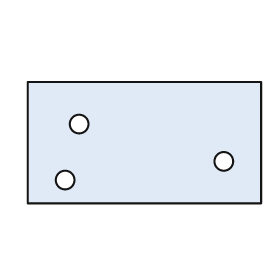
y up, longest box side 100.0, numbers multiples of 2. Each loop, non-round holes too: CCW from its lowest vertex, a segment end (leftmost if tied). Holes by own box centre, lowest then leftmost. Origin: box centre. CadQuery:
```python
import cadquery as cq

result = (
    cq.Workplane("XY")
    .moveTo(-50.0, -26.0)
    .lineTo(50.0, -26.0)
    .lineTo(50.0, 26.0)
    .lineTo(-50.0, 26.0)
    .close()
    .moveTo(-34.0, -16.0)
    .circle(4.0)
    .moveTo(34.0, -8.0)
    .circle(4.0)
    .moveTo(-28.0, 8.0)
    .circle(4.0)
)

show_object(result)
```